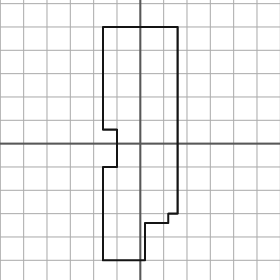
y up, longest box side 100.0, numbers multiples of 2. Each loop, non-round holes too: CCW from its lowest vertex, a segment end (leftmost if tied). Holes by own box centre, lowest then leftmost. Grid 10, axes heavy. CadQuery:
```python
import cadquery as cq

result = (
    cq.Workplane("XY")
    .moveTo(-16.0, -50.0)
    .lineTo(2.0, -50.0)
    .lineTo(2.0, -34.0)
    .lineTo(12.0, -34.0)
    .lineTo(12.0, -30.0)
    .lineTo(16.0, -30.0)
    .lineTo(16.0, 50.0)
    .lineTo(-16.0, 50.0)
    .lineTo(-16.0, 6.0)
    .lineTo(-10.0, 6.0)
    .lineTo(-10.0, -10.0)
    .lineTo(-16.0, -10.0)
    .close()
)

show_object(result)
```